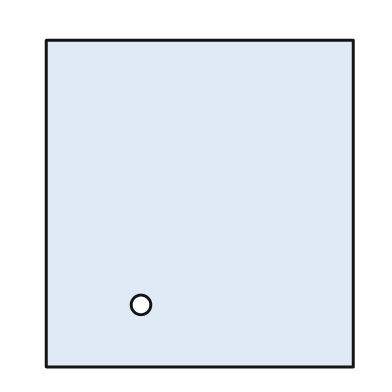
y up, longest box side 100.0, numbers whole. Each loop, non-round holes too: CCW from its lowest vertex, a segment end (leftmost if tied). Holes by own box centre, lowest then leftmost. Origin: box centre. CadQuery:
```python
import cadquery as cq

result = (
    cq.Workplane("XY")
    .moveTo(-47.0, -50.0)
    .lineTo(47.0, -50.0)
    .lineTo(47.0, 50.0)
    .lineTo(-47.0, 50.0)
    .close()
    .moveTo(-18.0, -31.0)
    .circle(3.0)
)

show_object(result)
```